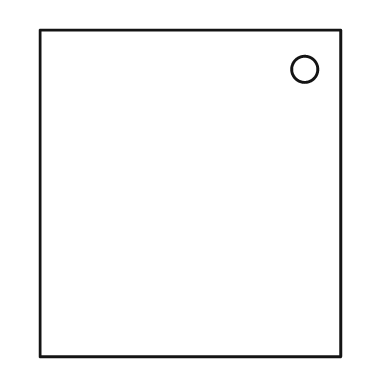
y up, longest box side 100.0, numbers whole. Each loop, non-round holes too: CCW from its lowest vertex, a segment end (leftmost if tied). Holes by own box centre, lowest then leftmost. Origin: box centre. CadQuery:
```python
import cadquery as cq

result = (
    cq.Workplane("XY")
    .moveTo(-46.0, -50.0)
    .lineTo(46.0, -50.0)
    .lineTo(46.0, 50.0)
    .lineTo(-46.0, 50.0)
    .close()
    .moveTo(35.0, 38.0)
    .circle(4.0)
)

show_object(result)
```